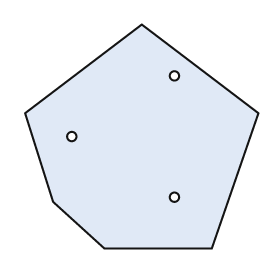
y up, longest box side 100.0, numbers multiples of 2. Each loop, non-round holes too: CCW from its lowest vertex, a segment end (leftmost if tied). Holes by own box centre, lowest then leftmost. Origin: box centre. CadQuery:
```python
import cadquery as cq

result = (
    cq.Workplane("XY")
    .moveTo(-16.0, -48.0)
    .lineTo(30.0, -48.0)
    .lineTo(50.0, 10.0)
    .lineTo(0.0, 48.0)
    .lineTo(-50.0, 10.0)
    .lineTo(-38.0, -28.0)
    .close()
    .moveTo(14.0, -26.0)
    .circle(2.0)
    .moveTo(-30.0, 0.0)
    .circle(2.0)
    .moveTo(14.0, 26.0)
    .circle(2.0)
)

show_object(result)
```